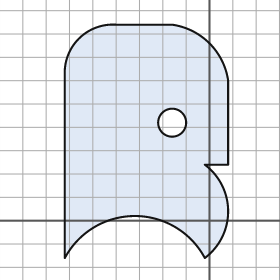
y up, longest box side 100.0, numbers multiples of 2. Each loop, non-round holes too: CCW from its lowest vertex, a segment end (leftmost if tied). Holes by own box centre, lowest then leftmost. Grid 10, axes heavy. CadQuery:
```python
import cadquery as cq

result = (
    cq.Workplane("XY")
    .moveTo(-62.0, -16.0)
    .threePointArc((-32.0, 2.0), (-2.0, -16.0))
    .threePointArc((8.0, 4.0), (-2.0, 24.0))
    .lineTo(8.0, 24.0)
    .lineTo(8.0, 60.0)
    .threePointArc((0.0, 76.0), (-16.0, 84.0))
    .lineTo(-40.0, 84.0)
    .threePointArc((-56.0, 78.0), (-62.0, 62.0))
    .close()
    .moveTo(-16.0, 42.0)
    .circle(6.0)
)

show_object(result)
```